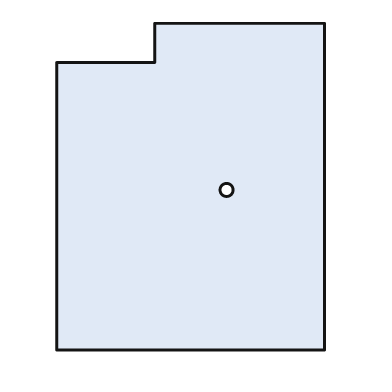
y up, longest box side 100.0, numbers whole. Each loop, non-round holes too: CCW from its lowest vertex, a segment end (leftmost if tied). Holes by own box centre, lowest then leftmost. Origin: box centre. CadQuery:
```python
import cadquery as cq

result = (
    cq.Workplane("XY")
    .moveTo(-41.0, -50.0)
    .lineTo(41.0, -50.0)
    .lineTo(41.0, 50.0)
    .lineTo(-11.0, 50.0)
    .lineTo(-11.0, 38.0)
    .lineTo(-41.0, 38.0)
    .close()
    .moveTo(11.0, -1.0)
    .circle(2.0)
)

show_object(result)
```